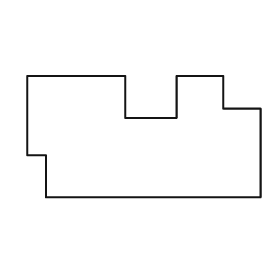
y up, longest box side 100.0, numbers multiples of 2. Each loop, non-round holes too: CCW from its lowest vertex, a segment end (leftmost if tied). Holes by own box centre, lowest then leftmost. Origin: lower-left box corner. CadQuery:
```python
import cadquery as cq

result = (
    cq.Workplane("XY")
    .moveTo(8.0, 0.0)
    .lineTo(100.0, 0.0)
    .lineTo(100.0, 38.0)
    .lineTo(84.0, 38.0)
    .lineTo(84.0, 52.0)
    .lineTo(64.0, 52.0)
    .lineTo(64.0, 34.0)
    .lineTo(42.0, 34.0)
    .lineTo(42.0, 52.0)
    .lineTo(0.0, 52.0)
    .lineTo(0.0, 18.0)
    .lineTo(8.0, 18.0)
    .close()
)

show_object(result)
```